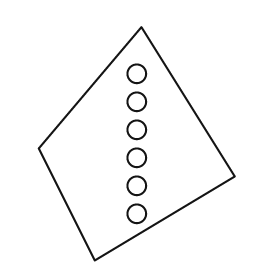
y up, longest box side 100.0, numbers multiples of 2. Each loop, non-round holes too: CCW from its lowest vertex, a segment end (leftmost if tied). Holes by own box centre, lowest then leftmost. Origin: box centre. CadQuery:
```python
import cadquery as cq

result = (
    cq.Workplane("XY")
    .moveTo(-18.0, -50.0)
    .lineTo(42.0, -14.0)
    .lineTo(2.0, 50.0)
    .lineTo(-42.0, -2.0)
    .close()
    .moveTo(0.0, -30.0)
    .circle(4.0)
    .moveTo(0.0, -18.0)
    .circle(4.0)
    .moveTo(0.0, -6.0)
    .circle(4.0)
    .moveTo(0.0, 6.0)
    .circle(4.0)
    .moveTo(0.0, 18.0)
    .circle(4.0)
    .moveTo(0.0, 30.0)
    .circle(4.0)
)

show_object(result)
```